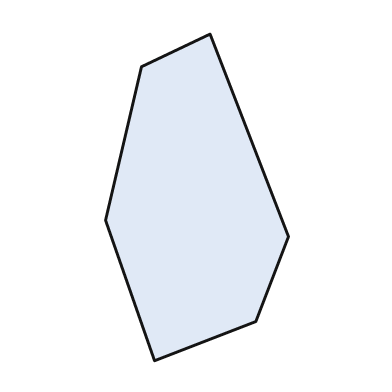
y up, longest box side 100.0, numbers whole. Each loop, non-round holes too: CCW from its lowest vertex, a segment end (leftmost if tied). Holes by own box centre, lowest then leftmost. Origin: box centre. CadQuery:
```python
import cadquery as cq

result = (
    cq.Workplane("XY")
    .moveTo(-13.0, -50.0)
    .lineTo(18.0, -38.0)
    .lineTo(28.0, -12.0)
    .lineTo(4.0, 50.0)
    .lineTo(-17.0, 40.0)
    .lineTo(-28.0, -7.0)
    .close()
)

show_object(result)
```